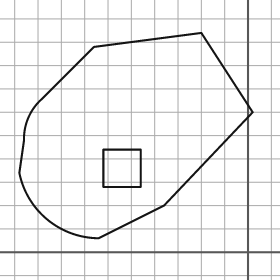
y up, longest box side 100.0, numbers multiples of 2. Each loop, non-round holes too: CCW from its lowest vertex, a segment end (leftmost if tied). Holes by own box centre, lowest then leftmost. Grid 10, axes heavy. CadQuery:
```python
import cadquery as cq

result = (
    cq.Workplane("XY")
    .moveTo(-64.0, 6.0)
    .lineTo(-36.0, 20.0)
    .lineTo(2.0, 60.0)
    .lineTo(-20.0, 94.0)
    .lineTo(-66.0, 88.0)
    .lineTo(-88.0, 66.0)
    .threePointArc((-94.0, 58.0), (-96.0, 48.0))
    .lineTo(-98.0, 34.0)
    .threePointArc((-86.0, 14.0), (-64.0, 6.0))
    .close()
    .moveTo(-62.0, 28.0)
    .lineTo(-46.0, 28.0)
    .lineTo(-46.0, 44.0)
    .lineTo(-62.0, 44.0)
    .close()
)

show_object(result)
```